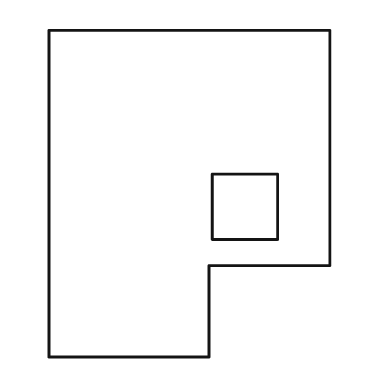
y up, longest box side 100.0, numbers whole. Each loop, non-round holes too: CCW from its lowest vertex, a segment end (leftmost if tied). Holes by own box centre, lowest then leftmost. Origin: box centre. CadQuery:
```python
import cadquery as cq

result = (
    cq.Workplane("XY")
    .moveTo(-43.0, -50.0)
    .lineTo(6.0, -50.0)
    .lineTo(6.0, -22.0)
    .lineTo(43.0, -22.0)
    .lineTo(43.0, 50.0)
    .lineTo(-43.0, 50.0)
    .close()
    .moveTo(7.0, -14.0)
    .lineTo(27.0, -14.0)
    .lineTo(27.0, 6.0)
    .lineTo(7.0, 6.0)
    .close()
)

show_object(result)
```